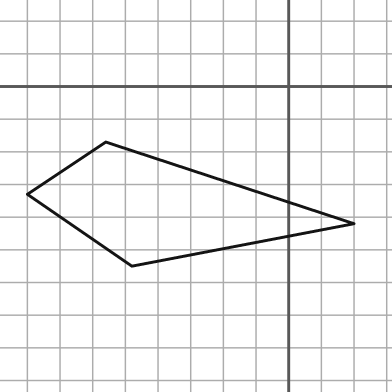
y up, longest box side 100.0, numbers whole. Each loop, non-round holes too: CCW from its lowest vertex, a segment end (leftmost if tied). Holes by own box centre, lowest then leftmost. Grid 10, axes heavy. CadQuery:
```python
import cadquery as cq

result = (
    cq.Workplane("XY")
    .moveTo(-48.0, -55.0)
    .lineTo(20.0, -42.0)
    .lineTo(-56.0, -17.0)
    .lineTo(-80.0, -33.0)
    .close()
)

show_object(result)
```